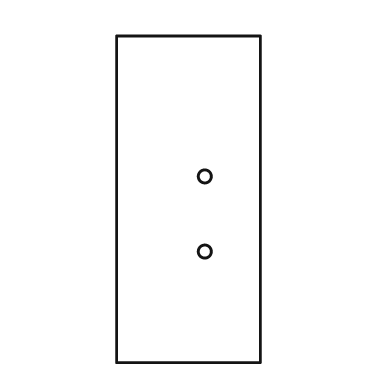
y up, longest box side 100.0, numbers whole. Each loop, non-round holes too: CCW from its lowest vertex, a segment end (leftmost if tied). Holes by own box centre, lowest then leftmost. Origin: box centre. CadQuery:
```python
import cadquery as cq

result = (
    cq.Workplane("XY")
    .moveTo(-22.0, -50.0)
    .lineTo(22.0, -50.0)
    .lineTo(22.0, 50.0)
    .lineTo(-22.0, 50.0)
    .close()
    .moveTo(5.0, -16.0)
    .circle(2.0)
    .moveTo(5.0, 7.0)
    .circle(2.0)
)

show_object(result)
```